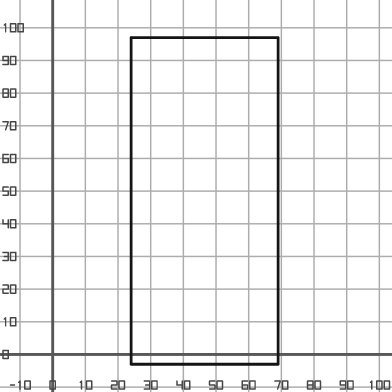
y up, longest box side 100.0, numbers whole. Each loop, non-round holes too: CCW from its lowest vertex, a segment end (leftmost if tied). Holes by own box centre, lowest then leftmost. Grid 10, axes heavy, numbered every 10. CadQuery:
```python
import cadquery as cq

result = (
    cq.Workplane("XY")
    .moveTo(24.0, -3.0)
    .lineTo(69.0, -3.0)
    .lineTo(69.0, 97.0)
    .lineTo(24.0, 97.0)
    .close()
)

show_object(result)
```